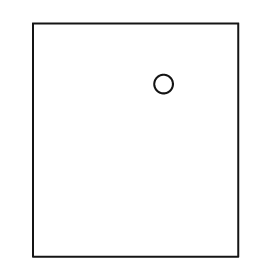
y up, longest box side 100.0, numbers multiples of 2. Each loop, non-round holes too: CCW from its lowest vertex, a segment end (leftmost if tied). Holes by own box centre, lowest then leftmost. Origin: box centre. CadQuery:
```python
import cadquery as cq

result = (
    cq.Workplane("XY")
    .moveTo(-44.0, -50.0)
    .lineTo(44.0, -50.0)
    .lineTo(44.0, 50.0)
    .lineTo(-44.0, 50.0)
    .close()
    .moveTo(12.0, 24.0)
    .circle(4.0)
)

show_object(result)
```